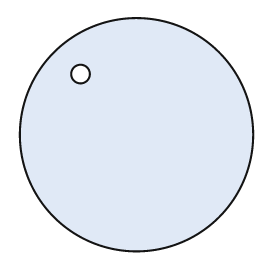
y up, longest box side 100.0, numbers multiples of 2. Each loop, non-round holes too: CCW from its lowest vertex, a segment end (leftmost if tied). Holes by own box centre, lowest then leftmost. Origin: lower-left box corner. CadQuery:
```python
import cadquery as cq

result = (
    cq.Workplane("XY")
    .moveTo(50.0, 50.0)
    .circle(50.0)
    .moveTo(26.0, 76.0)
    .circle(4.0)
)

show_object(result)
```